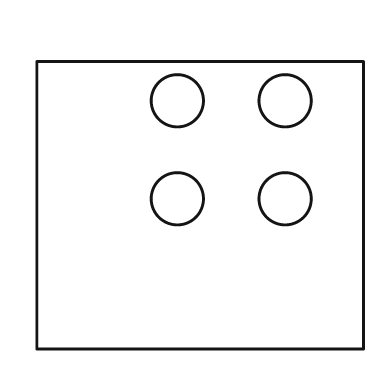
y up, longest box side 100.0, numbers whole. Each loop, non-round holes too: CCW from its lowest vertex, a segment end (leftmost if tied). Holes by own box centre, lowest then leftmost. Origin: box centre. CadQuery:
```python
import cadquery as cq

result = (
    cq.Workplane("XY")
    .moveTo(-50.0, -44.0)
    .lineTo(50.0, -44.0)
    .lineTo(50.0, 44.0)
    .lineTo(-50.0, 44.0)
    .close()
    .moveTo(-7.0, 2.0)
    .circle(8.0)
    .moveTo(26.0, 2.0)
    .circle(8.0)
    .moveTo(-7.0, 32.0)
    .circle(8.0)
    .moveTo(26.0, 32.0)
    .circle(8.0)
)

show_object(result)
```